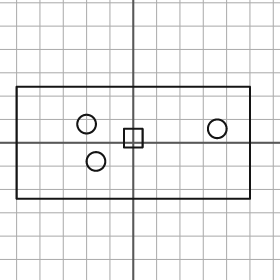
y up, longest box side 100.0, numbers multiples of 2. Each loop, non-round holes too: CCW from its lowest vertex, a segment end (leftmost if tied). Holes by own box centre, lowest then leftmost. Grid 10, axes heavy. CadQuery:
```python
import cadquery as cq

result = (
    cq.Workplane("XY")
    .moveTo(-50.0, -24.0)
    .lineTo(50.0, -24.0)
    .lineTo(50.0, 24.0)
    .lineTo(-50.0, 24.0)
    .close()
    .moveTo(-16.0, -8.0)
    .circle(4.0)
    .moveTo(-4.0, -2.0)
    .lineTo(4.0, -2.0)
    .lineTo(4.0, 6.0)
    .lineTo(-4.0, 6.0)
    .close()
    .moveTo(36.0, 6.0)
    .circle(4.0)
    .moveTo(-20.0, 8.0)
    .circle(4.0)
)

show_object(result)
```